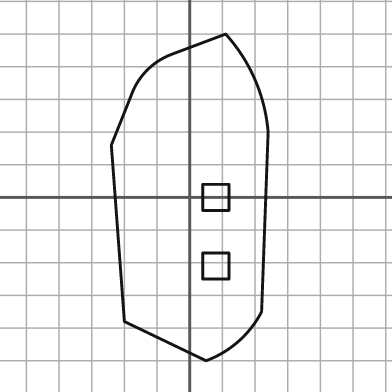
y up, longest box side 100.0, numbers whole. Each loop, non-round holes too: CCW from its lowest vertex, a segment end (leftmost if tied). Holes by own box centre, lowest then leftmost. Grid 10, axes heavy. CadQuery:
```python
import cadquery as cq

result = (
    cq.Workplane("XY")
    .moveTo(5.0, -50.0)
    .threePointArc((15.0, -44.0), (22.0, -35.0))
    .lineTo(24.0, 20.0)
    .threePointArc((20.0, 36.0), (11.0, 50.0))
    .lineTo(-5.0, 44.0)
    .threePointArc((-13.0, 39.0), (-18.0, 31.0))
    .lineTo(-24.0, 16.0)
    .lineTo(-20.0, -38.0)
    .close()
    .moveTo(4.0, -25.0)
    .lineTo(12.0, -25.0)
    .lineTo(12.0, -17.0)
    .lineTo(4.0, -17.0)
    .close()
    .moveTo(4.0, -4.0)
    .lineTo(12.0, -4.0)
    .lineTo(12.0, 4.0)
    .lineTo(4.0, 4.0)
    .close()
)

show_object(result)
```